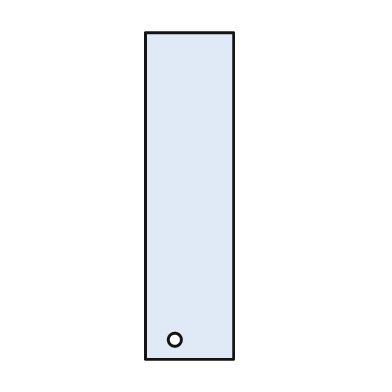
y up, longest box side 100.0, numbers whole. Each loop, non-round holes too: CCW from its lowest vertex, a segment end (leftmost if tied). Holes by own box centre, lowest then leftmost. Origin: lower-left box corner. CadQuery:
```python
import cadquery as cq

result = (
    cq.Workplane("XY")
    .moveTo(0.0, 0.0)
    .lineTo(27.0, 0.0)
    .lineTo(27.0, 100.0)
    .lineTo(0.0, 100.0)
    .close()
    .moveTo(9.0, 6.0)
    .circle(2.0)
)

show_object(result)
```